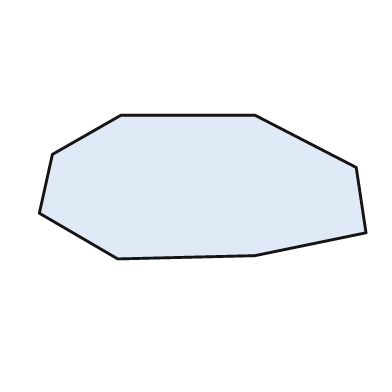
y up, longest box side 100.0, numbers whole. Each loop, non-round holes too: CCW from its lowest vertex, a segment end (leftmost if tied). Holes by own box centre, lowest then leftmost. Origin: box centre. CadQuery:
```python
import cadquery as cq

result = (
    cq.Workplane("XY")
    .moveTo(-26.0, -22.0)
    .lineTo(16.0, -21.0)
    .lineTo(50.0, -14.0)
    .lineTo(47.0, 6.0)
    .lineTo(16.0, 22.0)
    .lineTo(-25.0, 22.0)
    .lineTo(-46.0, 10.0)
    .lineTo(-50.0, -8.0)
    .close()
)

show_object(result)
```